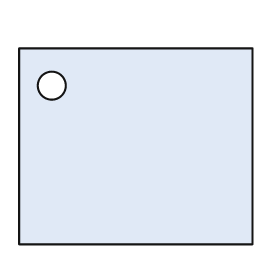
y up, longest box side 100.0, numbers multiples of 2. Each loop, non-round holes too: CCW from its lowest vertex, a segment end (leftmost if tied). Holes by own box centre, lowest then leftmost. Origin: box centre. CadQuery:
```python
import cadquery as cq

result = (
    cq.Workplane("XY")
    .moveTo(-50.0, -42.0)
    .lineTo(50.0, -42.0)
    .lineTo(50.0, 42.0)
    .lineTo(-50.0, 42.0)
    .close()
    .moveTo(-36.0, 26.0)
    .circle(6.0)
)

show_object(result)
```